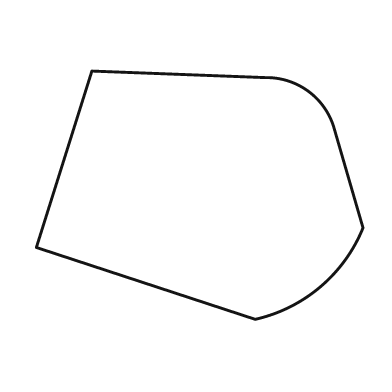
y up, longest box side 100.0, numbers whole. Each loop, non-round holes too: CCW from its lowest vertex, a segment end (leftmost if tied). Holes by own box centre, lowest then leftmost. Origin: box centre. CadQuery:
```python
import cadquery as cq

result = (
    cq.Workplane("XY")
    .moveTo(17.0, -38.0)
    .threePointArc((37.0, -28.0), (50.0, -10.0))
    .lineTo(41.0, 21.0)
    .threePointArc((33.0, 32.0), (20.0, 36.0))
    .lineTo(-33.0, 38.0)
    .lineTo(-50.0, -16.0)
    .close()
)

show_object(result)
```